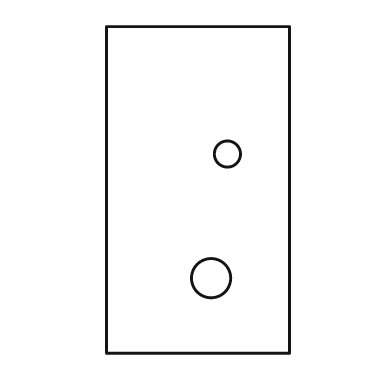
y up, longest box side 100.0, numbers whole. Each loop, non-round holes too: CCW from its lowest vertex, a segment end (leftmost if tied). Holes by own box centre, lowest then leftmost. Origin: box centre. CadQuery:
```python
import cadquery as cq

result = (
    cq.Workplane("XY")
    .moveTo(-28.0, -50.0)
    .lineTo(28.0, -50.0)
    .lineTo(28.0, 50.0)
    .lineTo(-28.0, 50.0)
    .close()
    .moveTo(4.0, -27.0)
    .circle(6.0)
    .moveTo(9.0, 11.0)
    .circle(4.0)
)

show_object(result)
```